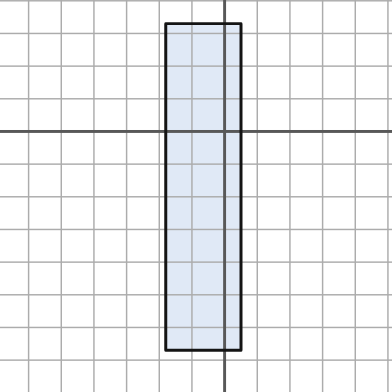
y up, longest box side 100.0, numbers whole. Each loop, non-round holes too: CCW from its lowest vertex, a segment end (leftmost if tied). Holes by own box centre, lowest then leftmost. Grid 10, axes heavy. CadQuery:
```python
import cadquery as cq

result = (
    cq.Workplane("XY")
    .moveTo(-18.0, -67.0)
    .lineTo(5.0, -67.0)
    .lineTo(5.0, 33.0)
    .lineTo(-18.0, 33.0)
    .close()
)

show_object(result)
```